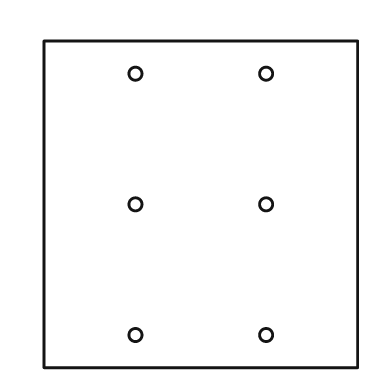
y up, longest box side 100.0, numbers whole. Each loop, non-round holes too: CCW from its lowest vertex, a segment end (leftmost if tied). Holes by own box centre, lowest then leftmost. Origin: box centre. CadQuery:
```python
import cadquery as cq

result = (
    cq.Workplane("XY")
    .moveTo(-48.0, -50.0)
    .lineTo(48.0, -50.0)
    .lineTo(48.0, 50.0)
    .lineTo(-48.0, 50.0)
    .close()
    .moveTo(-20.0, -40.0)
    .circle(2.0)
    .moveTo(20.0, -40.0)
    .circle(2.0)
    .moveTo(-20.0, 0.0)
    .circle(2.0)
    .moveTo(20.0, 0.0)
    .circle(2.0)
    .moveTo(-20.0, 40.0)
    .circle(2.0)
    .moveTo(20.0, 40.0)
    .circle(2.0)
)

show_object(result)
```